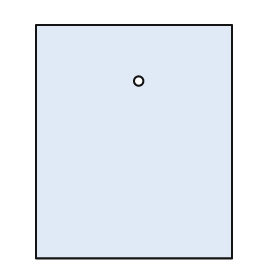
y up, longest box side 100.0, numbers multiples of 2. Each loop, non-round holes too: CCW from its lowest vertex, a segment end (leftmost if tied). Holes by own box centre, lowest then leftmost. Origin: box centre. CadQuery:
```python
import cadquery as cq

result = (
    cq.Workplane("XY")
    .moveTo(-42.0, -50.0)
    .lineTo(42.0, -50.0)
    .lineTo(42.0, 50.0)
    .lineTo(-42.0, 50.0)
    .close()
    .moveTo(2.0, 26.0)
    .circle(2.0)
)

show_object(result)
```